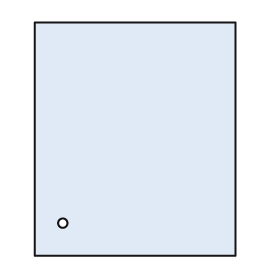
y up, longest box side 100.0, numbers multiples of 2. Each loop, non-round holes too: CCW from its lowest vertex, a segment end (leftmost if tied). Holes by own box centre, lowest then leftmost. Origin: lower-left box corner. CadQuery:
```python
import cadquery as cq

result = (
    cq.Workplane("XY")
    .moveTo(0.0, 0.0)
    .lineTo(86.0, 0.0)
    .lineTo(86.0, 100.0)
    .lineTo(0.0, 100.0)
    .close()
    .moveTo(12.0, 14.0)
    .circle(2.0)
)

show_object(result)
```